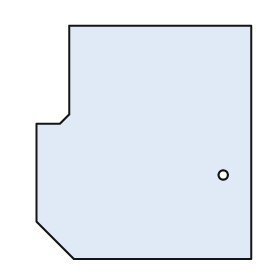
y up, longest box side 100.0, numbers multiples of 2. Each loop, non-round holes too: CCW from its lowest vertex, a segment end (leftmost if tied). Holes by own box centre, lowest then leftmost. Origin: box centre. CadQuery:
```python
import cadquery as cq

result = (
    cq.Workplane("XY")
    .moveTo(-30.0, -50.0)
    .lineTo(46.0, -50.0)
    .lineTo(46.0, 50.0)
    .lineTo(-32.0, 50.0)
    .lineTo(-32.0, 12.0)
    .lineTo(-36.0, 8.0)
    .lineTo(-46.0, 8.0)
    .lineTo(-46.0, -34.0)
    .close()
    .moveTo(34.0, -14.0)
    .circle(2.0)
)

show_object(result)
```